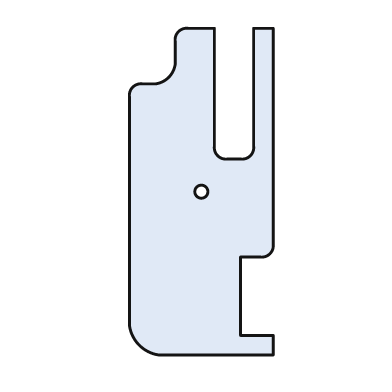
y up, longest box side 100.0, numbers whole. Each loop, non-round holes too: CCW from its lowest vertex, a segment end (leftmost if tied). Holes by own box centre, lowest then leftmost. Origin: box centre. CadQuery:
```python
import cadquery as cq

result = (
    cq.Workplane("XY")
    .moveTo(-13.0, -50.0)
    .lineTo(22.0, -50.0)
    .lineTo(22.0, -44.0)
    .lineTo(12.0, -44.0)
    .lineTo(12.0, -20.0)
    .lineTo(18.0, -20.0)
    .threePointArc((21.0, -19.0), (22.0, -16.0))
    .lineTo(22.0, 50.0)
    .lineTo(16.0, 50.0)
    .lineTo(16.0, 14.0)
    .threePointArc((15.0, 11.0), (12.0, 10.0))
    .lineTo(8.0, 10.0)
    .threePointArc((5.0, 11.0), (4.0, 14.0))
    .lineTo(4.0, 50.0)
    .lineTo(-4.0, 50.0)
    .threePointArc((-7.0, 49.0), (-8.0, 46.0))
    .lineTo(-8.0, 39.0)
    .threePointArc((-10.0, 35.0), (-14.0, 33.0))
    .lineTo(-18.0, 33.0)
    .threePointArc((-21.0, 32.0), (-22.0, 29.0))
    .lineTo(-22.0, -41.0)
    .threePointArc((-19.0, -47.0), (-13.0, -50.0))
    .close()
    .moveTo(0.0, 0.0)
    .circle(2.0)
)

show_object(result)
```